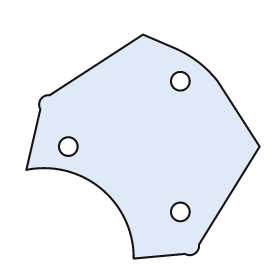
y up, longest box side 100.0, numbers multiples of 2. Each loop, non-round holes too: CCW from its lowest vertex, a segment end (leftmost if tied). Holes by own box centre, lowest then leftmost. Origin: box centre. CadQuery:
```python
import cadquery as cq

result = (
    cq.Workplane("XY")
    .moveTo(-4.0, -48.0)
    .lineTo(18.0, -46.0)
    .threePointArc((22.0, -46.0), (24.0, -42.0))
    .lineTo(50.0, 0.0)
    .lineTo(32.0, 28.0)
    .threePointArc((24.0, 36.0), (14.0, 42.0))
    .lineTo(0.0, 48.0)
    .lineTo(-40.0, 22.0)
    .threePointArc((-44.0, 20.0), (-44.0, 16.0))
    .lineTo(-50.0, -10.0)
    .threePointArc((-18.0, -18.0), (-4.0, -48.0))
    .close()
    .moveTo(16.0, -28.0)
    .circle(4.0)
    .moveTo(-32.0, 0.0)
    .circle(4.0)
    .moveTo(16.0, 28.0)
    .circle(4.0)
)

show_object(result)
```